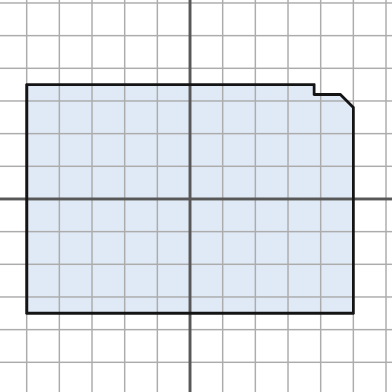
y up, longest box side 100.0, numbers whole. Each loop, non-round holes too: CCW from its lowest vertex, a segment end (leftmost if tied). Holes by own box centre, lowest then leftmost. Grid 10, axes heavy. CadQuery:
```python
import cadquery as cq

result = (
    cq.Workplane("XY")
    .moveTo(-50.0, -35.0)
    .lineTo(50.0, -35.0)
    .lineTo(50.0, 28.0)
    .lineTo(46.0, 32.0)
    .lineTo(38.0, 32.0)
    .lineTo(38.0, 35.0)
    .lineTo(-50.0, 35.0)
    .close()
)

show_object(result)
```